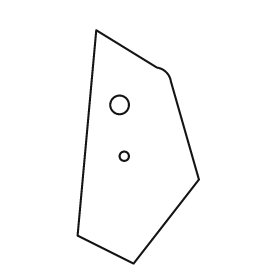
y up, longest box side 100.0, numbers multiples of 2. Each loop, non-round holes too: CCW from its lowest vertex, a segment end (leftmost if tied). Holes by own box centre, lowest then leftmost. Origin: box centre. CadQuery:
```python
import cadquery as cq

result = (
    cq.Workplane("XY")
    .moveTo(-2.0, -50.0)
    .lineTo(26.0, -14.0)
    .lineTo(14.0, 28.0)
    .threePointArc((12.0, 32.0), (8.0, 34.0))
    .lineTo(-18.0, 50.0)
    .lineTo(-26.0, -38.0)
    .close()
    .moveTo(-6.0, -4.0)
    .circle(2.0)
    .moveTo(-8.0, 18.0)
    .circle(4.0)
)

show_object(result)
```